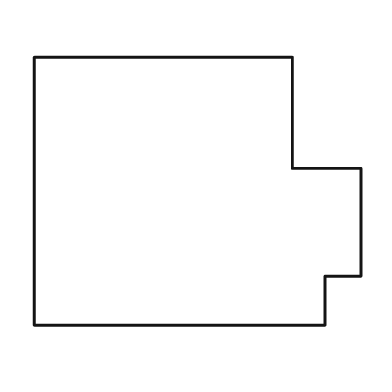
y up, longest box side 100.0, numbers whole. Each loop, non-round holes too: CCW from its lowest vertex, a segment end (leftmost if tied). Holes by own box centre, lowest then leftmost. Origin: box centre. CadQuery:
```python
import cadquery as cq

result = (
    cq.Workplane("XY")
    .moveTo(-50.0, -41.0)
    .lineTo(39.0, -41.0)
    .lineTo(39.0, -26.0)
    .lineTo(50.0, -26.0)
    .lineTo(50.0, 7.0)
    .lineTo(29.0, 7.0)
    .lineTo(29.0, 41.0)
    .lineTo(-50.0, 41.0)
    .close()
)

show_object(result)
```